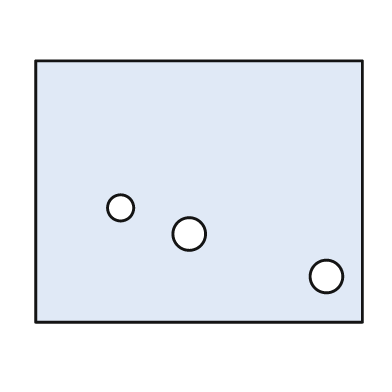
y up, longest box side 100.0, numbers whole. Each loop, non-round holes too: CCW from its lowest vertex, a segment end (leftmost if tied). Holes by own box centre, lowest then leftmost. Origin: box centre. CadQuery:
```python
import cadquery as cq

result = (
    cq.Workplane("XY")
    .moveTo(-50.0, -40.0)
    .lineTo(50.0, -40.0)
    .lineTo(50.0, 40.0)
    .lineTo(-50.0, 40.0)
    .close()
    .moveTo(39.0, -26.0)
    .circle(5.0)
    .moveTo(-3.0, -13.0)
    .circle(5.0)
    .moveTo(-24.0, -5.0)
    .circle(4.0)
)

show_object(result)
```